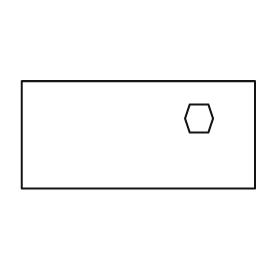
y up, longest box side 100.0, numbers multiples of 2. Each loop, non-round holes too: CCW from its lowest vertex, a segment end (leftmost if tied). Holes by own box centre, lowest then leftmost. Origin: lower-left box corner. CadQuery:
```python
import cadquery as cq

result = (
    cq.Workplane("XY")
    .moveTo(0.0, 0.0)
    .lineTo(100.0, 0.0)
    .lineTo(100.0, 46.0)
    .lineTo(0.0, 46.0)
    .close()
    .moveTo(72.0, 24.0)
    .lineTo(80.0, 24.0)
    .lineTo(82.0, 30.0)
    .lineTo(80.0, 36.0)
    .lineTo(72.0, 36.0)
    .lineTo(70.0, 30.0)
    .close()
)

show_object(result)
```